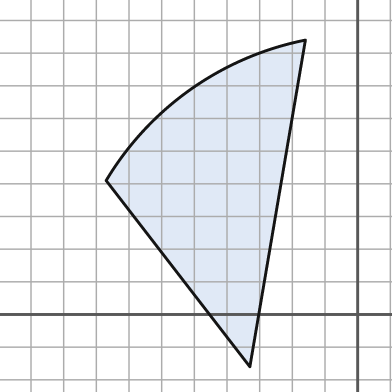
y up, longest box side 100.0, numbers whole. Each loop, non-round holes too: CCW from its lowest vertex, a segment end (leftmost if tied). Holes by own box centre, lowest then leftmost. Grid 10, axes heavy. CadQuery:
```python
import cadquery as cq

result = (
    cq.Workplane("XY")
    .moveTo(-33.0, -16.0)
    .lineTo(-16.0, 84.0)
    .threePointArc((-51.0, 69.0), (-77.0, 41.0))
    .close()
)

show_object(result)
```